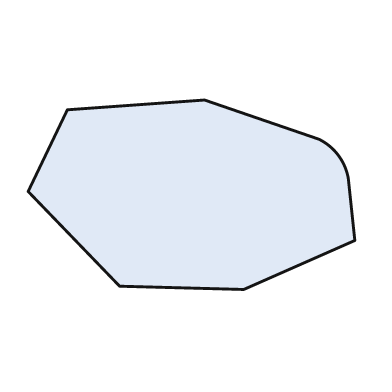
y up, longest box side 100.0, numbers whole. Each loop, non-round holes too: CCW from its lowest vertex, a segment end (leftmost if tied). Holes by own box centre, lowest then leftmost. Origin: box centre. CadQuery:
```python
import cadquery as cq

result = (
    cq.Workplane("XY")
    .moveTo(16.0, -29.0)
    .lineTo(50.0, -14.0)
    .lineTo(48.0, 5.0)
    .threePointArc((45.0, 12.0), (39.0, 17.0))
    .lineTo(4.0, 29.0)
    .lineTo(-38.0, 26.0)
    .lineTo(-50.0, 1.0)
    .lineTo(-22.0, -28.0)
    .close()
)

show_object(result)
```